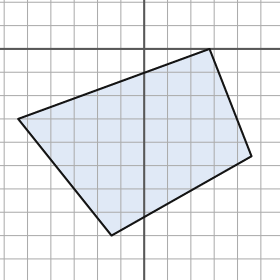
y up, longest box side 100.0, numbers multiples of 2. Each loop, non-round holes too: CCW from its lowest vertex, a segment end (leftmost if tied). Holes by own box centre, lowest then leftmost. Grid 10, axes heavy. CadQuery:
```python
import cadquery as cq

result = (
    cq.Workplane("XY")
    .moveTo(-14.0, -80.0)
    .lineTo(46.0, -46.0)
    .lineTo(28.0, 0.0)
    .lineTo(-54.0, -30.0)
    .close()
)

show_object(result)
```